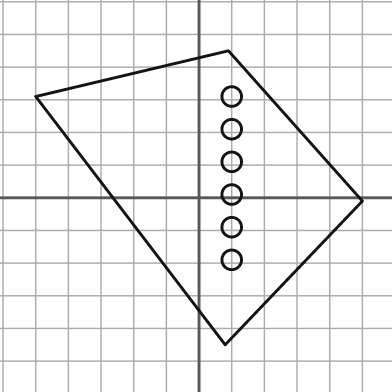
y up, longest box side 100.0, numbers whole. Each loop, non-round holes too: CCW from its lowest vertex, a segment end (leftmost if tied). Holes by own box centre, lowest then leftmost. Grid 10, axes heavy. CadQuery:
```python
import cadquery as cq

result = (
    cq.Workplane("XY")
    .moveTo(8.0, -45.0)
    .lineTo(50.0, -1.0)
    .lineTo(9.0, 45.0)
    .lineTo(-50.0, 31.0)
    .close()
    .moveTo(10.0, -19.0)
    .circle(3.0)
    .moveTo(10.0, -9.0)
    .circle(3.0)
    .moveTo(10.0, 1.0)
    .circle(3.0)
    .moveTo(10.0, 11.0)
    .circle(3.0)
    .moveTo(10.0, 21.0)
    .circle(3.0)
    .moveTo(10.0, 31.0)
    .circle(3.0)
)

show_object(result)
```